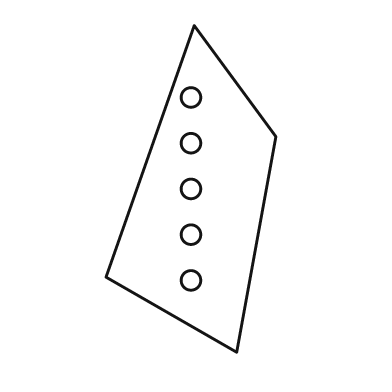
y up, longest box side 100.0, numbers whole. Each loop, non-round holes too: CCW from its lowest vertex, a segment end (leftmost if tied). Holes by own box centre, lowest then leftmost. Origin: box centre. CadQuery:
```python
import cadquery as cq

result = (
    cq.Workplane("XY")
    .moveTo(14.0, -50.0)
    .lineTo(26.0, 16.0)
    .lineTo(1.0, 50.0)
    .lineTo(-26.0, -27.0)
    .close()
    .moveTo(0.0, -28.0)
    .circle(3.0)
    .moveTo(0.0, -14.0)
    .circle(3.0)
    .moveTo(0.0, 0.0)
    .circle(3.0)
    .moveTo(0.0, 14.0)
    .circle(3.0)
    .moveTo(0.0, 28.0)
    .circle(3.0)
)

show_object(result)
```